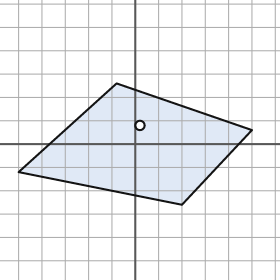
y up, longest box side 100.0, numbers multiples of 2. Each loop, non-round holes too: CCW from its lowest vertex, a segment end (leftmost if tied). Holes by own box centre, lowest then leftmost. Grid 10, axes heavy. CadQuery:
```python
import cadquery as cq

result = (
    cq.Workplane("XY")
    .moveTo(20.0, -26.0)
    .lineTo(50.0, 6.0)
    .lineTo(-8.0, 26.0)
    .lineTo(-50.0, -12.0)
    .close()
    .moveTo(2.0, 8.0)
    .circle(2.0)
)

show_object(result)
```